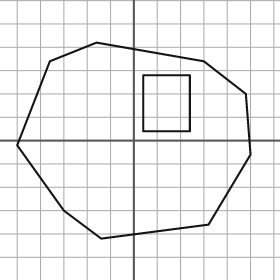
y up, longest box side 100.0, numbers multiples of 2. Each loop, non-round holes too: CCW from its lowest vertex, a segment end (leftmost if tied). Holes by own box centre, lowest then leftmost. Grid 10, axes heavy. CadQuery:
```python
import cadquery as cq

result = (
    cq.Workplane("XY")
    .moveTo(-14.0, -42.0)
    .lineTo(32.0, -36.0)
    .lineTo(50.0, -6.0)
    .lineTo(48.0, 20.0)
    .lineTo(30.0, 34.0)
    .lineTo(-16.0, 42.0)
    .lineTo(-36.0, 34.0)
    .lineTo(-50.0, -2.0)
    .lineTo(-30.0, -30.0)
    .close()
    .moveTo(4.0, 4.0)
    .lineTo(24.0, 4.0)
    .lineTo(24.0, 28.0)
    .lineTo(4.0, 28.0)
    .close()
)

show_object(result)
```